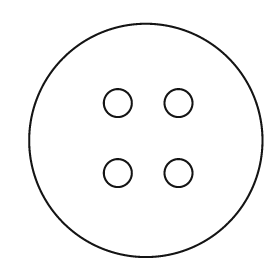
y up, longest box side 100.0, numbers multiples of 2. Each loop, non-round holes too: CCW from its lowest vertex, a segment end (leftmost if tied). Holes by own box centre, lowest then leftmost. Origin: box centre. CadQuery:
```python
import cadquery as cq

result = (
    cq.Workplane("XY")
    .moveTo(0.0, 0.0)
    .circle(50.0)
    .moveTo(-12.0, -14.0)
    .circle(6.0)
    .moveTo(14.0, -14.0)
    .circle(6.0)
    .moveTo(-12.0, 16.0)
    .circle(6.0)
    .moveTo(14.0, 16.0)
    .circle(6.0)
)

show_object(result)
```